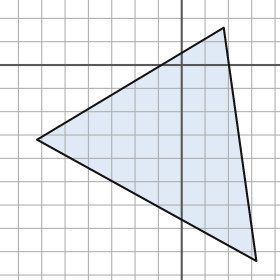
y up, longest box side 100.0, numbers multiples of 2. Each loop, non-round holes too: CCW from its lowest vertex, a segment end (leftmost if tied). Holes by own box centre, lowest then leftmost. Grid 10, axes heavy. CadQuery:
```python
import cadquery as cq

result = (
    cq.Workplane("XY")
    .moveTo(32.0, -84.0)
    .lineTo(18.0, 16.0)
    .lineTo(-62.0, -32.0)
    .close()
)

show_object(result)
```